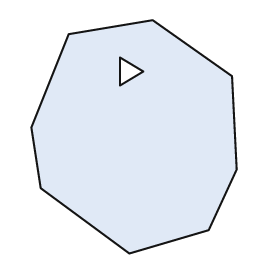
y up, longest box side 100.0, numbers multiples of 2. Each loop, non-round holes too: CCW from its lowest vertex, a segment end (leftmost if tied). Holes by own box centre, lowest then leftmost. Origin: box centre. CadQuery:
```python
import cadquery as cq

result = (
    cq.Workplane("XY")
    .moveTo(-2.0, -50.0)
    .lineTo(32.0, -40.0)
    .lineTo(44.0, -14.0)
    .lineTo(42.0, 26.0)
    .lineTo(8.0, 50.0)
    .lineTo(-28.0, 44.0)
    .lineTo(-44.0, 4.0)
    .lineTo(-40.0, -22.0)
    .close()
    .moveTo(-6.0, 22.0)
    .lineTo(4.0, 28.0)
    .lineTo(-6.0, 34.0)
    .close()
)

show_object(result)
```